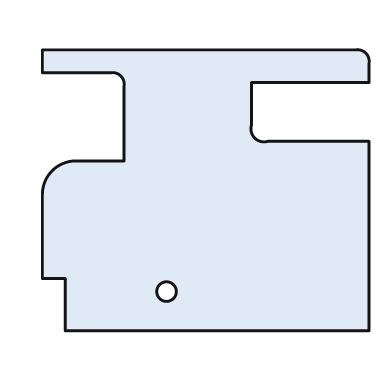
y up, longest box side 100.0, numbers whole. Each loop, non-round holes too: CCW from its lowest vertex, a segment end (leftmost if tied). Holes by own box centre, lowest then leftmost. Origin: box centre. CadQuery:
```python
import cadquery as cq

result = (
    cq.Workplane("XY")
    .moveTo(-43.0, -43.0)
    .lineTo(50.0, -43.0)
    .lineTo(50.0, 15.0)
    .lineTo(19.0, 15.0)
    .threePointArc((15.0, 16.0), (14.0, 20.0))
    .lineTo(14.0, 33.0)
    .lineTo(50.0, 33.0)
    .lineTo(50.0, 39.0)
    .threePointArc((49.0, 42.0), (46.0, 43.0))
    .lineTo(-50.0, 43.0)
    .lineTo(-50.0, 36.0)
    .lineTo(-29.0, 36.0)
    .threePointArc((-26.0, 35.0), (-25.0, 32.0))
    .lineTo(-25.0, 9.0)
    .lineTo(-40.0, 9.0)
    .threePointArc((-47.0, 6.0), (-50.0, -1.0))
    .lineTo(-50.0, -27.0)
    .lineTo(-43.0, -27.0)
    .close()
    .moveTo(-12.0, -31.0)
    .circle(3.0)
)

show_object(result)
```